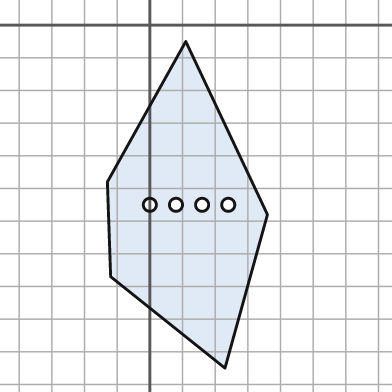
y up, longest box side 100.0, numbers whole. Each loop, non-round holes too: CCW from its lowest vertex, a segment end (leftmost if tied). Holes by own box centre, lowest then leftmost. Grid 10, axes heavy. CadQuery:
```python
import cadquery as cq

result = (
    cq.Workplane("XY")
    .moveTo(23.0, -105.0)
    .lineTo(36.0, -58.0)
    .lineTo(11.0, -5.0)
    .lineTo(-13.0, -48.0)
    .lineTo(-12.0, -77.0)
    .close()
    .moveTo(0.0, -55.0)
    .circle(2.0)
    .moveTo(8.0, -55.0)
    .circle(2.0)
    .moveTo(16.0, -55.0)
    .circle(2.0)
    .moveTo(24.0, -55.0)
    .circle(2.0)
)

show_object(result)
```